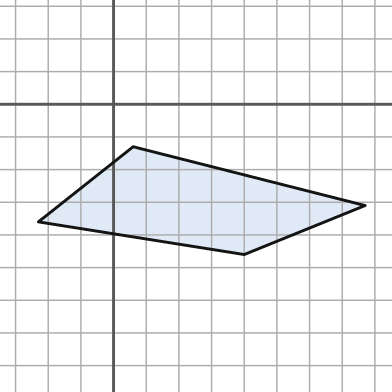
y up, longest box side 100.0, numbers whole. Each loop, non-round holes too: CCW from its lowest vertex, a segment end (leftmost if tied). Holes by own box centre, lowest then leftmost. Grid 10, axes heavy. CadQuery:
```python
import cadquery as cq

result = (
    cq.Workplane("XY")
    .moveTo(40.0, -46.0)
    .lineTo(77.0, -31.0)
    .lineTo(6.0, -13.0)
    .lineTo(-23.0, -36.0)
    .close()
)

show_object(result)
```